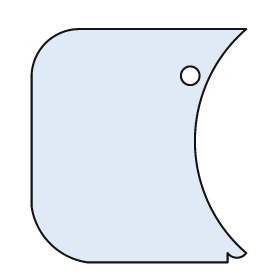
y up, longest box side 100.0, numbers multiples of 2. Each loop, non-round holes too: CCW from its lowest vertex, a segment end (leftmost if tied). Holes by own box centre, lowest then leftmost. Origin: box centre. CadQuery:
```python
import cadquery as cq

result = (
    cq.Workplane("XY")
    .moveTo(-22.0, -50.0)
    .lineTo(38.0, -50.0)
    .lineTo(38.0, -46.0)
    .threePointArc((42.0, -48.0), (46.0, -46.0))
    .threePointArc((24.0, 2.0), (46.0, 50.0))
    .lineTo(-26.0, 50.0)
    .threePointArc((-40.0, 44.0), (-46.0, 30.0))
    .lineTo(-46.0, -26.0)
    .threePointArc((-38.0, -42.0), (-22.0, -50.0))
    .close()
    .moveTo(22.0, 30.0)
    .circle(4.0)
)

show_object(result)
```